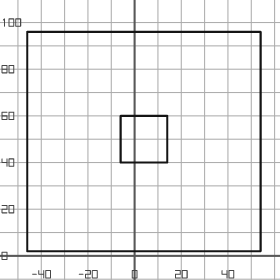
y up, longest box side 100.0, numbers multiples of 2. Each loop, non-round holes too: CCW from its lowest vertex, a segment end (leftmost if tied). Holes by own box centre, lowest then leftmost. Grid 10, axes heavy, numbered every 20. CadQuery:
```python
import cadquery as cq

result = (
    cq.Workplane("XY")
    .moveTo(-46.0, 2.0)
    .lineTo(54.0, 2.0)
    .lineTo(54.0, 96.0)
    .lineTo(-46.0, 96.0)
    .close()
    .moveTo(-6.0, 40.0)
    .lineTo(14.0, 40.0)
    .lineTo(14.0, 60.0)
    .lineTo(-6.0, 60.0)
    .close()
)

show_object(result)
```